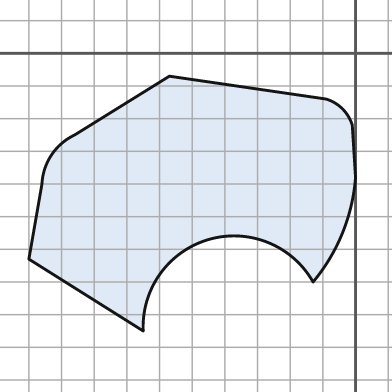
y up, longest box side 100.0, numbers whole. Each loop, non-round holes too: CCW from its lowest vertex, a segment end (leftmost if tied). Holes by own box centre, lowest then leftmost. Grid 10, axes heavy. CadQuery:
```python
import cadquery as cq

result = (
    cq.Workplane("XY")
    .moveTo(-65.0, -85.0)
    .threePointArc((-45.0, -57.0), (-13.0, -70.0))
    .threePointArc((-4.0, -55.0), (0.0, -38.0))
    .lineTo(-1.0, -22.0)
    .threePointArc((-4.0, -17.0), (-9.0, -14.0))
    .lineTo(-57.0, -7.0)
    .lineTo(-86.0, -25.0)
    .threePointArc((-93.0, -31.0), (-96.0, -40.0))
    .lineTo(-100.0, -63.0)
    .close()
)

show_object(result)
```